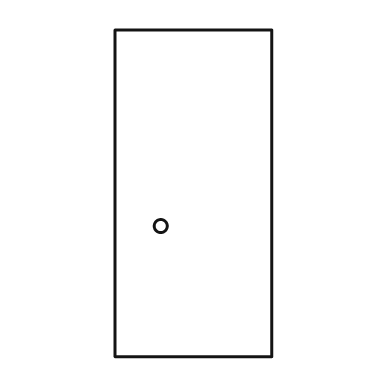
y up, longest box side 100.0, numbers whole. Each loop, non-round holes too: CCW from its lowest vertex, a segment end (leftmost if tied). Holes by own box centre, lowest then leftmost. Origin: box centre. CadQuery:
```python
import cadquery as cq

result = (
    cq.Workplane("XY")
    .moveTo(-24.0, -50.0)
    .lineTo(24.0, -50.0)
    .lineTo(24.0, 50.0)
    .lineTo(-24.0, 50.0)
    .close()
    .moveTo(-10.0, -10.0)
    .circle(2.0)
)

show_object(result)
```